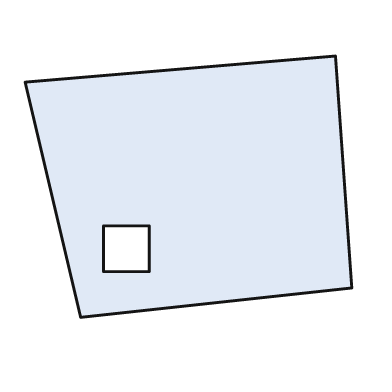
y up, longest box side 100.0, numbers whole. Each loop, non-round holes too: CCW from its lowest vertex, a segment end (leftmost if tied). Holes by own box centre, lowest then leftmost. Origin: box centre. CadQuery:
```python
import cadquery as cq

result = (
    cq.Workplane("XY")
    .moveTo(-33.0, -40.0)
    .lineTo(50.0, -31.0)
    .lineTo(45.0, 40.0)
    .lineTo(-50.0, 32.0)
    .close()
    .moveTo(-26.0, -26.0)
    .lineTo(-12.0, -26.0)
    .lineTo(-12.0, -12.0)
    .lineTo(-26.0, -12.0)
    .close()
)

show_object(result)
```